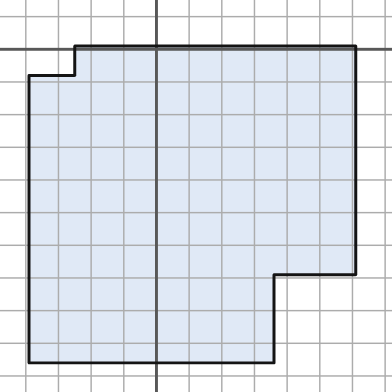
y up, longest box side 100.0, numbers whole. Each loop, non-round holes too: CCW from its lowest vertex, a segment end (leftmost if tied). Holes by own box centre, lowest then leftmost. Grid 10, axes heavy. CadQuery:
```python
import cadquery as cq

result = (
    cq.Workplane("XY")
    .moveTo(-39.0, -96.0)
    .lineTo(36.0, -96.0)
    .lineTo(36.0, -69.0)
    .lineTo(61.0, -69.0)
    .lineTo(61.0, 1.0)
    .lineTo(-25.0, 1.0)
    .lineTo(-25.0, -8.0)
    .lineTo(-39.0, -8.0)
    .close()
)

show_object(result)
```